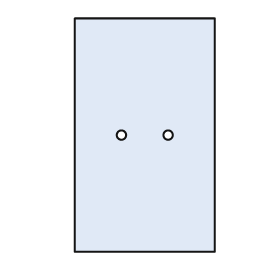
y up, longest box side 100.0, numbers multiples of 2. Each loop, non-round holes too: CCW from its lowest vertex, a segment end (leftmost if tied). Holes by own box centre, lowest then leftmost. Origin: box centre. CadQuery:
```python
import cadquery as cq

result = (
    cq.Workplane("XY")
    .moveTo(-30.0, -50.0)
    .lineTo(30.0, -50.0)
    .lineTo(30.0, 50.0)
    .lineTo(-30.0, 50.0)
    .close()
    .moveTo(-10.0, 0.0)
    .circle(2.0)
    .moveTo(10.0, 0.0)
    .circle(2.0)
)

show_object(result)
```